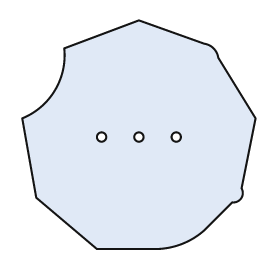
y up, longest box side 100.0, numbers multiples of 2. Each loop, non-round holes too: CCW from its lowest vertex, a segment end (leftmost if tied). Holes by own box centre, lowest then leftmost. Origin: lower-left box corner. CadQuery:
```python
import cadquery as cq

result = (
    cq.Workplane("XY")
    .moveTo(32.0, 0.0)
    .lineTo(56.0, 0.0)
    .threePointArc((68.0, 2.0), (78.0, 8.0))
    .lineTo(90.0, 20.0)
    .threePointArc((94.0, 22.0), (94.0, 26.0))
    .lineTo(100.0, 56.0)
    .lineTo(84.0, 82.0)
    .threePointArc((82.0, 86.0), (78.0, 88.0))
    .lineTo(50.0, 98.0)
    .lineTo(18.0, 86.0)
    .threePointArc((14.0, 68.0), (0.0, 56.0))
    .lineTo(6.0, 22.0)
    .close()
    .moveTo(34.0, 48.0)
    .circle(2.0)
    .moveTo(50.0, 48.0)
    .circle(2.0)
    .moveTo(66.0, 48.0)
    .circle(2.0)
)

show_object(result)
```